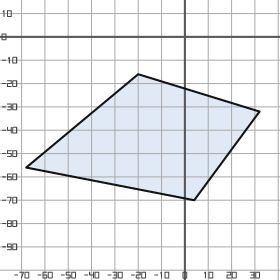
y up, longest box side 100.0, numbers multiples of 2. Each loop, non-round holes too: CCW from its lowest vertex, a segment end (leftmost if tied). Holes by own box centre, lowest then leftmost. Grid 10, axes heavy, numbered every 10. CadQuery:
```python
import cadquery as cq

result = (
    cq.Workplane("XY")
    .moveTo(4.0, -70.0)
    .lineTo(32.0, -32.0)
    .lineTo(-20.0, -16.0)
    .lineTo(-68.0, -56.0)
    .close()
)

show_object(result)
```